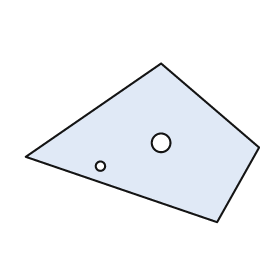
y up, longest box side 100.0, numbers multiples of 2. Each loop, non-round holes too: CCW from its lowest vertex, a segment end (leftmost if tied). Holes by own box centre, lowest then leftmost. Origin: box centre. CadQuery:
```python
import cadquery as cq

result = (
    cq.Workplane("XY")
    .moveTo(32.0, -34.0)
    .lineTo(50.0, -2.0)
    .lineTo(8.0, 34.0)
    .lineTo(-50.0, -6.0)
    .close()
    .moveTo(-18.0, -10.0)
    .circle(2.0)
    .moveTo(8.0, 0.0)
    .circle(4.0)
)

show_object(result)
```